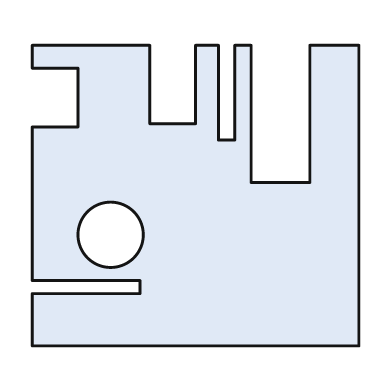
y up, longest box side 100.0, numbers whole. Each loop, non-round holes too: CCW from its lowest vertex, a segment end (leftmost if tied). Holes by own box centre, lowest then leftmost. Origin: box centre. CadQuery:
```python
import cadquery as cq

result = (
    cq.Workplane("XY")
    .moveTo(-50.0, -46.0)
    .lineTo(50.0, -46.0)
    .lineTo(50.0, 46.0)
    .lineTo(35.0, 46.0)
    .lineTo(35.0, 4.0)
    .lineTo(17.0, 4.0)
    .lineTo(17.0, 46.0)
    .lineTo(12.0, 46.0)
    .lineTo(12.0, 17.0)
    .lineTo(7.0, 17.0)
    .lineTo(7.0, 46.0)
    .lineTo(0.0, 46.0)
    .lineTo(0.0, 22.0)
    .lineTo(-14.0, 22.0)
    .lineTo(-14.0, 46.0)
    .lineTo(-50.0, 46.0)
    .lineTo(-50.0, 39.0)
    .lineTo(-36.0, 39.0)
    .lineTo(-36.0, 21.0)
    .lineTo(-50.0, 21.0)
    .lineTo(-50.0, -26.0)
    .lineTo(-17.0, -26.0)
    .lineTo(-17.0, -30.0)
    .lineTo(-50.0, -30.0)
    .close()
    .moveTo(-26.0, -12.0)
    .circle(10.0)
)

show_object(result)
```